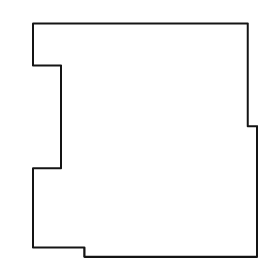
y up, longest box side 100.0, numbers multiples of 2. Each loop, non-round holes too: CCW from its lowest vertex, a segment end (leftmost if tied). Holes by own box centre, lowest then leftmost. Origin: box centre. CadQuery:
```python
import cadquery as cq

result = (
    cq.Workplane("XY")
    .moveTo(-26.0, -50.0)
    .lineTo(48.0, -50.0)
    .lineTo(48.0, 6.0)
    .lineTo(44.0, 6.0)
    .lineTo(44.0, 50.0)
    .lineTo(-48.0, 50.0)
    .lineTo(-48.0, 32.0)
    .lineTo(-36.0, 32.0)
    .lineTo(-36.0, -12.0)
    .lineTo(-48.0, -12.0)
    .lineTo(-48.0, -46.0)
    .lineTo(-26.0, -46.0)
    .close()
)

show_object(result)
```